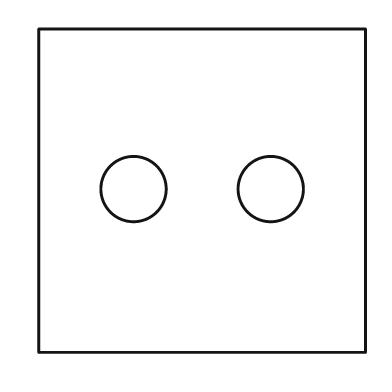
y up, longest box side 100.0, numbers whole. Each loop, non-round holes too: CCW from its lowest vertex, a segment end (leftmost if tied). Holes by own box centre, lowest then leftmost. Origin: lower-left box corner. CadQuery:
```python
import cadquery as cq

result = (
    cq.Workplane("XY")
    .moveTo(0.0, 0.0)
    .lineTo(100.0, 0.0)
    .lineTo(100.0, 99.0)
    .lineTo(0.0, 99.0)
    .close()
    .moveTo(29.0, 50.0)
    .circle(10.0)
    .moveTo(71.0, 50.0)
    .circle(10.0)
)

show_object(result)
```